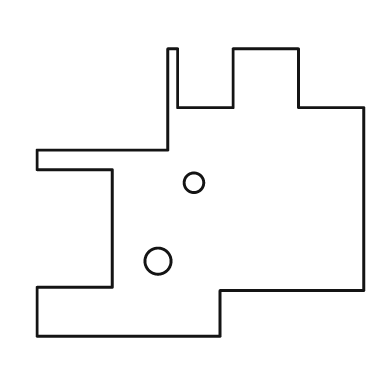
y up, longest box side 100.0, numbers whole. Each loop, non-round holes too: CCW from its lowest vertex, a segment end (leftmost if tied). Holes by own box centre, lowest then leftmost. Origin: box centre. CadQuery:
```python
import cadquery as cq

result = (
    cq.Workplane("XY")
    .moveTo(-50.0, -44.0)
    .lineTo(6.0, -44.0)
    .lineTo(6.0, -30.0)
    .lineTo(50.0, -30.0)
    .lineTo(50.0, 26.0)
    .lineTo(30.0, 26.0)
    .lineTo(30.0, 44.0)
    .lineTo(10.0, 44.0)
    .lineTo(10.0, 26.0)
    .lineTo(-7.0, 26.0)
    .lineTo(-7.0, 44.0)
    .lineTo(-10.0, 44.0)
    .lineTo(-10.0, 13.0)
    .lineTo(-50.0, 13.0)
    .lineTo(-50.0, 7.0)
    .lineTo(-27.0, 7.0)
    .lineTo(-27.0, -29.0)
    .lineTo(-50.0, -29.0)
    .close()
    .moveTo(-13.0, -21.0)
    .circle(4.0)
    .moveTo(-2.0, 3.0)
    .circle(3.0)
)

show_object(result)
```